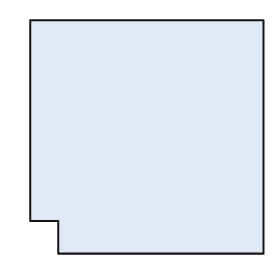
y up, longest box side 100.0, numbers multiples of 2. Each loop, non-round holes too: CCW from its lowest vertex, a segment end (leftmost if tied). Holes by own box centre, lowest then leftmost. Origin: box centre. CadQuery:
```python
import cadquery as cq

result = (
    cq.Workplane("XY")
    .moveTo(-38.0, -50.0)
    .lineTo(50.0, -50.0)
    .lineTo(50.0, 50.0)
    .lineTo(-50.0, 50.0)
    .lineTo(-50.0, -36.0)
    .lineTo(-38.0, -36.0)
    .close()
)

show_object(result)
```